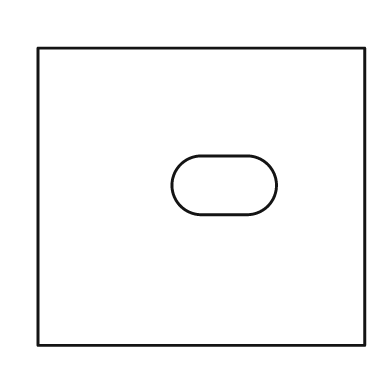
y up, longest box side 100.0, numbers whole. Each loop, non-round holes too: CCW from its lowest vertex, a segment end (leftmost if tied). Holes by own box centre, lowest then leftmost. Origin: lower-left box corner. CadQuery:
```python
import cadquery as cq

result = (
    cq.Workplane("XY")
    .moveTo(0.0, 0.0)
    .lineTo(100.0, 0.0)
    .lineTo(100.0, 91.0)
    .lineTo(0.0, 91.0)
    .close()
    .moveTo(50.0, 40.0)
    .lineTo(64.0, 40.0)
    .threePointArc((73.0, 49.0), (64.0, 58.0))
    .lineTo(50.0, 58.0)
    .threePointArc((41.0, 49.0), (50.0, 40.0))
    .close()
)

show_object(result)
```